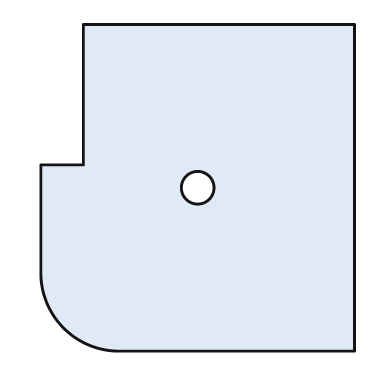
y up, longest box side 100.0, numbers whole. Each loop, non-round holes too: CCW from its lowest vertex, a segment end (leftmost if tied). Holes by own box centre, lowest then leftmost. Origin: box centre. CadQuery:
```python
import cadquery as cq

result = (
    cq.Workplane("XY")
    .moveTo(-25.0, -50.0)
    .lineTo(48.0, -50.0)
    .lineTo(48.0, 50.0)
    .lineTo(-35.0, 50.0)
    .lineTo(-35.0, 7.0)
    .lineTo(-48.0, 7.0)
    .lineTo(-48.0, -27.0)
    .threePointArc((-41.0, -43.0), (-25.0, -50.0))
    .close()
    .moveTo(0.0, 0.0)
    .circle(5.0)
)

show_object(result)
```